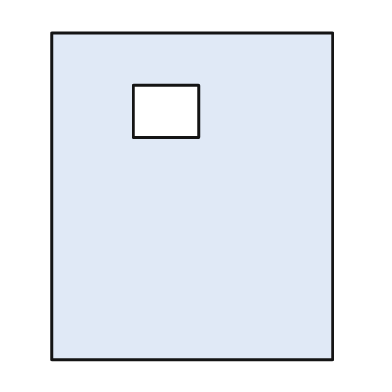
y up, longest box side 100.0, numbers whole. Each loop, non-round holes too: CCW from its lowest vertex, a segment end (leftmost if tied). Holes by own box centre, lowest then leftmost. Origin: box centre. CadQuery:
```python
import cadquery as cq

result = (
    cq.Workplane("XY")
    .moveTo(-43.0, -50.0)
    .lineTo(43.0, -50.0)
    .lineTo(43.0, 50.0)
    .lineTo(-43.0, 50.0)
    .close()
    .moveTo(-18.0, 18.0)
    .lineTo(2.0, 18.0)
    .lineTo(2.0, 34.0)
    .lineTo(-18.0, 34.0)
    .close()
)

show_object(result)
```